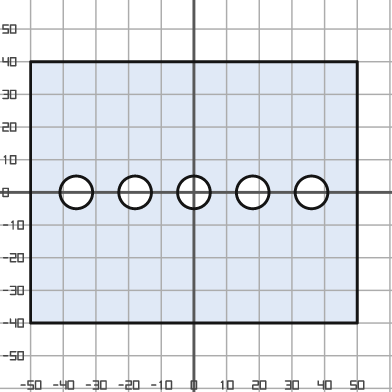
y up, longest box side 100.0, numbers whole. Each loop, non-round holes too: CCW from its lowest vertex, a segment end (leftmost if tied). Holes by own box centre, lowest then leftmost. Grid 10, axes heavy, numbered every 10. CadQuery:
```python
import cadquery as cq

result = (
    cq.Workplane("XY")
    .moveTo(-50.0, -40.0)
    .lineTo(50.0, -40.0)
    .lineTo(50.0, 40.0)
    .lineTo(-50.0, 40.0)
    .close()
    .moveTo(-36.0, 0.0)
    .circle(5.0)
    .moveTo(-18.0, 0.0)
    .circle(5.0)
    .moveTo(0.0, 0.0)
    .circle(5.0)
    .moveTo(18.0, 0.0)
    .circle(5.0)
    .moveTo(36.0, 0.0)
    .circle(5.0)
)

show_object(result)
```